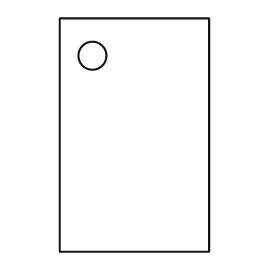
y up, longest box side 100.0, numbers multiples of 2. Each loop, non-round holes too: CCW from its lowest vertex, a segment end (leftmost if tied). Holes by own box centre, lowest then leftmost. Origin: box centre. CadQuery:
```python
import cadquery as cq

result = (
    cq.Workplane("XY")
    .moveTo(-32.0, -50.0)
    .lineTo(32.0, -50.0)
    .lineTo(32.0, 50.0)
    .lineTo(-32.0, 50.0)
    .close()
    .moveTo(-18.0, 34.0)
    .circle(6.0)
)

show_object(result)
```